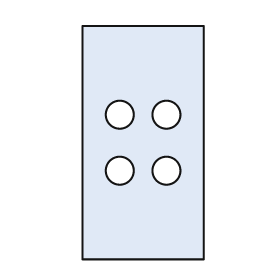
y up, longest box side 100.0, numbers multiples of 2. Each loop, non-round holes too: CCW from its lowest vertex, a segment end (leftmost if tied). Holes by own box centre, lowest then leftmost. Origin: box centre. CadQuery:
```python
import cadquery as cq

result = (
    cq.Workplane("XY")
    .moveTo(-26.0, -50.0)
    .lineTo(26.0, -50.0)
    .lineTo(26.0, 50.0)
    .lineTo(-26.0, 50.0)
    .close()
    .moveTo(-10.0, -12.0)
    .circle(6.0)
    .moveTo(10.0, -12.0)
    .circle(6.0)
    .moveTo(-10.0, 12.0)
    .circle(6.0)
    .moveTo(10.0, 12.0)
    .circle(6.0)
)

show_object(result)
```